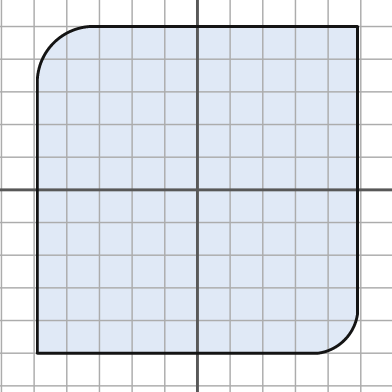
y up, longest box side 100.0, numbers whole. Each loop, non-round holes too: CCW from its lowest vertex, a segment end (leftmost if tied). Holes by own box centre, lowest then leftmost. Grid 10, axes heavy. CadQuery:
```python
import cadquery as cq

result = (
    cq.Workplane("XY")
    .moveTo(-49.0, -50.0)
    .lineTo(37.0, -50.0)
    .threePointArc((45.0, -46.0), (49.0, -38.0))
    .lineTo(49.0, 50.0)
    .lineTo(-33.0, 50.0)
    .threePointArc((-44.0, 45.0), (-49.0, 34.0))
    .close()
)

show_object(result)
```